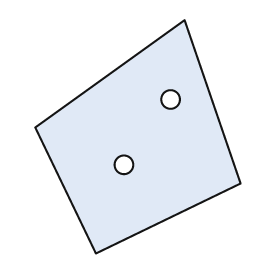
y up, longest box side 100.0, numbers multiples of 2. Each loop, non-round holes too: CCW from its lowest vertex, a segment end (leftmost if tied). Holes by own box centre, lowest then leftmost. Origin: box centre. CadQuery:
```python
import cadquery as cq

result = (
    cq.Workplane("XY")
    .moveTo(-18.0, -50.0)
    .lineTo(44.0, -20.0)
    .lineTo(20.0, 50.0)
    .lineTo(-44.0, 4.0)
    .close()
    .moveTo(-6.0, -12.0)
    .circle(4.0)
    .moveTo(14.0, 16.0)
    .circle(4.0)
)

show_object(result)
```